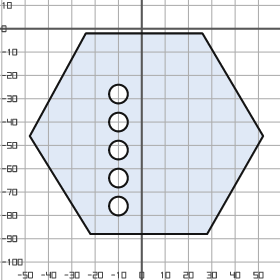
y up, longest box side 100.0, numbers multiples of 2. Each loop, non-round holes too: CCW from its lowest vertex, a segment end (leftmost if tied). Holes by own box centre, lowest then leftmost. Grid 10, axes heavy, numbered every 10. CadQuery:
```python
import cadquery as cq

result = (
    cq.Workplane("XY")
    .moveTo(-22.0, -88.0)
    .lineTo(28.0, -88.0)
    .lineTo(52.0, -46.0)
    .lineTo(26.0, -2.0)
    .lineTo(-24.0, -2.0)
    .lineTo(-48.0, -46.0)
    .close()
    .moveTo(-10.0, -76.0)
    .circle(4.0)
    .moveTo(-10.0, -64.0)
    .circle(4.0)
    .moveTo(-10.0, -52.0)
    .circle(4.0)
    .moveTo(-10.0, -40.0)
    .circle(4.0)
    .moveTo(-10.0, -28.0)
    .circle(4.0)
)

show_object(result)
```